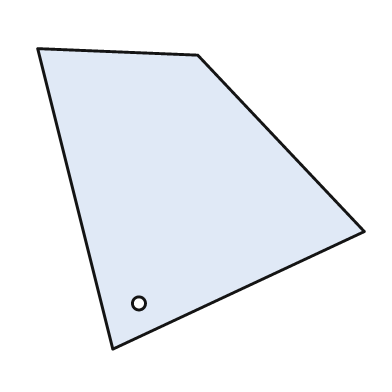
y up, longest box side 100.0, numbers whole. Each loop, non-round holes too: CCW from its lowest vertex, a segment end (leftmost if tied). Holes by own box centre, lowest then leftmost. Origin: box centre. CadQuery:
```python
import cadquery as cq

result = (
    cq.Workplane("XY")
    .moveTo(-27.0, -46.0)
    .lineTo(50.0, -10.0)
    .lineTo(-1.0, 44.0)
    .lineTo(-50.0, 46.0)
    .close()
    .moveTo(-19.0, -32.0)
    .circle(2.0)
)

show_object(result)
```